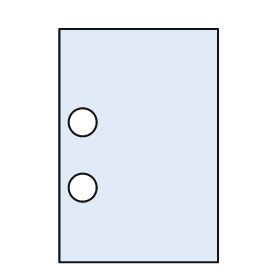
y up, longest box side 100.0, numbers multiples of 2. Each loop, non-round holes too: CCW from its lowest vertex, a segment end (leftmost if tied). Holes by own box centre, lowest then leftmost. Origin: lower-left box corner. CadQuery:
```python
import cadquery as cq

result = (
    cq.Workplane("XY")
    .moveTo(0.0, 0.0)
    .lineTo(68.0, 0.0)
    .lineTo(68.0, 100.0)
    .lineTo(0.0, 100.0)
    .close()
    .moveTo(10.0, 32.0)
    .circle(6.0)
    .moveTo(10.0, 60.0)
    .circle(6.0)
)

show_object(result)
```